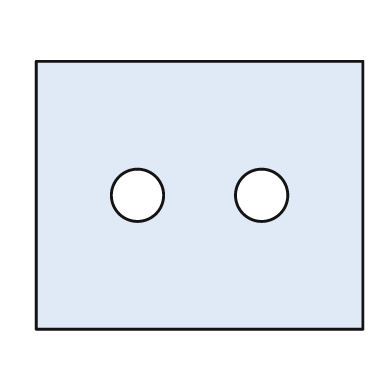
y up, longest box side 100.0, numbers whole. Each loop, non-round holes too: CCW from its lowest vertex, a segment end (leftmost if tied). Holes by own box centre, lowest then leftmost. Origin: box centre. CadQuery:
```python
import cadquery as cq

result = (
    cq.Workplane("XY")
    .moveTo(-50.0, -41.0)
    .lineTo(50.0, -41.0)
    .lineTo(50.0, 41.0)
    .lineTo(-50.0, 41.0)
    .close()
    .moveTo(-19.0, 0.0)
    .circle(8.0)
    .moveTo(19.0, 0.0)
    .circle(8.0)
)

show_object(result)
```